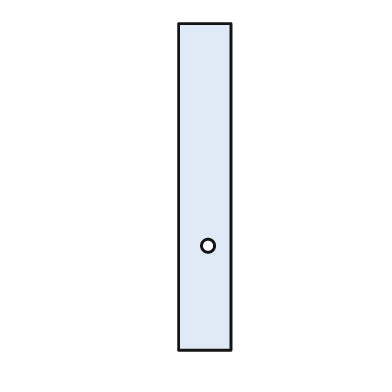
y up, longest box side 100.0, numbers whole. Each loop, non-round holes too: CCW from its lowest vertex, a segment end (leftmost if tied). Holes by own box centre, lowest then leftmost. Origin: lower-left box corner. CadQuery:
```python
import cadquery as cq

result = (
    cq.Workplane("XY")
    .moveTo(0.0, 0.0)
    .lineTo(16.0, 0.0)
    .lineTo(16.0, 100.0)
    .lineTo(0.0, 100.0)
    .close()
    .moveTo(9.0, 32.0)
    .circle(2.0)
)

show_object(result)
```